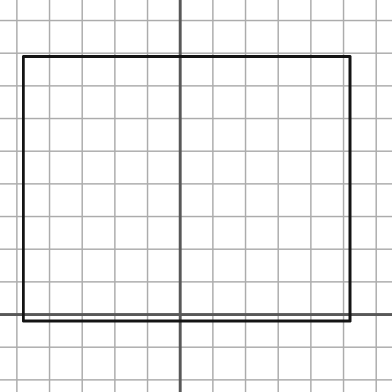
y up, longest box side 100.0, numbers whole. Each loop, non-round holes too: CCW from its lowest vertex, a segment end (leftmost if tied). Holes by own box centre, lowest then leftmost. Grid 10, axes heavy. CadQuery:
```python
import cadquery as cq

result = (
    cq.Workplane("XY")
    .moveTo(-48.0, -2.0)
    .lineTo(52.0, -2.0)
    .lineTo(52.0, 79.0)
    .lineTo(-48.0, 79.0)
    .close()
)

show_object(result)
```